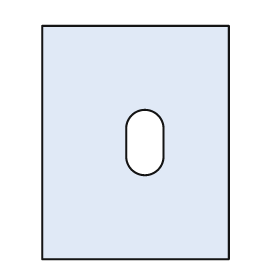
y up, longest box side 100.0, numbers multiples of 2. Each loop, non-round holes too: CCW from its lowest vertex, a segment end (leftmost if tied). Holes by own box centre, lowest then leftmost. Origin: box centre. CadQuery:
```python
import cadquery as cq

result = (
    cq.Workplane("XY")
    .moveTo(-40.0, -50.0)
    .lineTo(40.0, -50.0)
    .lineTo(40.0, 50.0)
    .lineTo(-40.0, 50.0)
    .close()
    .moveTo(-4.0, -6.0)
    .threePointArc((4.0, -14.0), (12.0, -6.0))
    .lineTo(12.0, 6.0)
    .threePointArc((4.0, 14.0), (-4.0, 6.0))
    .close()
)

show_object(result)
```